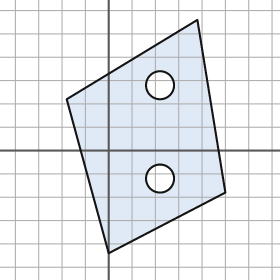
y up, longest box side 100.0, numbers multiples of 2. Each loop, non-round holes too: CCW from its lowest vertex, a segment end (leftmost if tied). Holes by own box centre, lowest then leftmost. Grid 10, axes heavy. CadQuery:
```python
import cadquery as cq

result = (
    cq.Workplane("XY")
    .moveTo(0.0, -44.0)
    .lineTo(50.0, -18.0)
    .lineTo(38.0, 56.0)
    .lineTo(-18.0, 22.0)
    .close()
    .moveTo(22.0, -12.0)
    .circle(6.0)
    .moveTo(22.0, 28.0)
    .circle(6.0)
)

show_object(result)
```